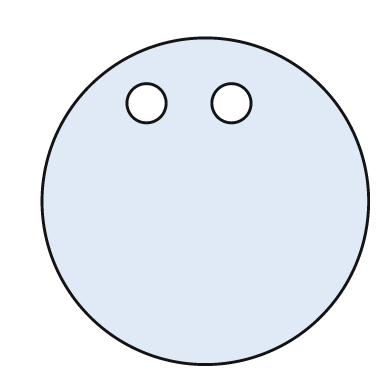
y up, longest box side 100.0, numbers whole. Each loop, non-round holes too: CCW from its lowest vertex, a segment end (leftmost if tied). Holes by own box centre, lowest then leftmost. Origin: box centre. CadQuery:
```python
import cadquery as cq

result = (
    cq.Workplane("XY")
    .moveTo(0.0, 0.0)
    .circle(50.0)
    .moveTo(-18.0, 30.0)
    .circle(6.0)
    .moveTo(8.0, 30.0)
    .circle(6.0)
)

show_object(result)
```